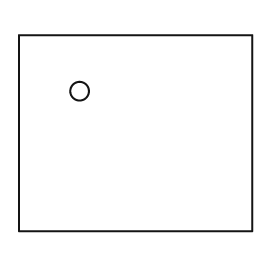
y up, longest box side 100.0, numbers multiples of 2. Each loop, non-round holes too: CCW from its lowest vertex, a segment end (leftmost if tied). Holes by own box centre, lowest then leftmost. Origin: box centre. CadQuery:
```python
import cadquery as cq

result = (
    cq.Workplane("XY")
    .moveTo(-50.0, -42.0)
    .lineTo(50.0, -42.0)
    .lineTo(50.0, 42.0)
    .lineTo(-50.0, 42.0)
    .close()
    .moveTo(-24.0, 18.0)
    .circle(4.0)
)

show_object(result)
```